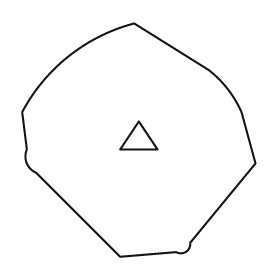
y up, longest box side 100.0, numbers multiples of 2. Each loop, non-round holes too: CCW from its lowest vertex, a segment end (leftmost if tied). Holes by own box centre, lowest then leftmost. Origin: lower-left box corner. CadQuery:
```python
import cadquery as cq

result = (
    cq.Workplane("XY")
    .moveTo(42.0, 0.0)
    .lineTo(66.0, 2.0)
    .threePointArc((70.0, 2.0), (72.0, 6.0))
    .lineTo(100.0, 40.0)
    .lineTo(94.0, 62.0)
    .threePointArc((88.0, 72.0), (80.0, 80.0))
    .lineTo(48.0, 100.0)
    .threePointArc((20.0, 86.0), (0.0, 62.0))
    .lineTo(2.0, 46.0)
    .threePointArc((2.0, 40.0), (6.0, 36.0))
    .close()
    .moveTo(42.0, 46.0)
    .lineTo(58.0, 46.0)
    .lineTo(50.0, 58.0)
    .close()
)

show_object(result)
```